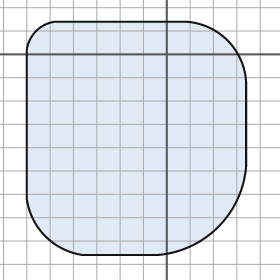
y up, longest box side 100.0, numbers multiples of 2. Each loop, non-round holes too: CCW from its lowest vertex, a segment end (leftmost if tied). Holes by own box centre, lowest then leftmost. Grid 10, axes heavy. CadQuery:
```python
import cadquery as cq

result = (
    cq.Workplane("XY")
    .moveTo(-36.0, -86.0)
    .lineTo(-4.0, -86.0)
    .threePointArc((22.0, -74.0), (34.0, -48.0))
    .lineTo(34.0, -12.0)
    .threePointArc((26.0, 6.0), (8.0, 14.0))
    .lineTo(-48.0, 14.0)
    .threePointArc((-56.0, 10.0), (-60.0, 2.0))
    .lineTo(-60.0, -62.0)
    .threePointArc((-52.0, -78.0), (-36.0, -86.0))
    .close()
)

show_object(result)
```